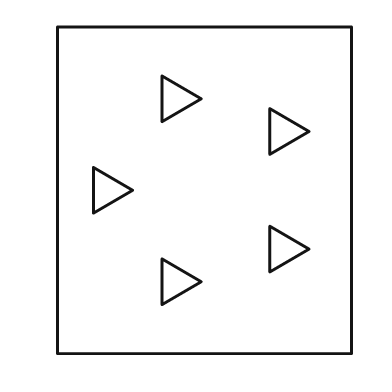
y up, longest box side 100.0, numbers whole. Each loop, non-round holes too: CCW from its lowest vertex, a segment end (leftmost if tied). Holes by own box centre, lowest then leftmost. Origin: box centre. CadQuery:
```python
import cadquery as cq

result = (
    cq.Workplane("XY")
    .moveTo(-45.0, -50.0)
    .lineTo(45.0, -50.0)
    .lineTo(45.0, 50.0)
    .lineTo(-45.0, 50.0)
    .close()
    .moveTo(-13.0, -35.0)
    .lineTo(-1.0, -28.0)
    .lineTo(-13.0, -21.0)
    .close()
    .moveTo(20.0, -25.0)
    .lineTo(32.0, -18.0)
    .lineTo(20.0, -11.0)
    .close()
    .moveTo(-34.0, -7.0)
    .lineTo(-22.0, 0.0)
    .lineTo(-34.0, 7.0)
    .close()
    .moveTo(20.0, 11.0)
    .lineTo(32.0, 18.0)
    .lineTo(20.0, 25.0)
    .close()
    .moveTo(-13.0, 21.0)
    .lineTo(-1.0, 28.0)
    .lineTo(-13.0, 35.0)
    .close()
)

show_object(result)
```